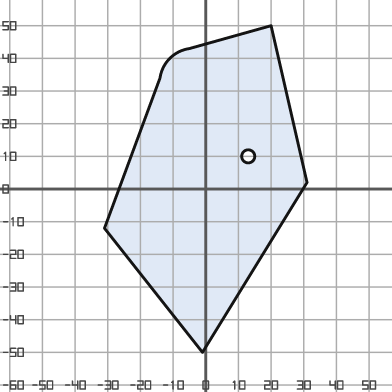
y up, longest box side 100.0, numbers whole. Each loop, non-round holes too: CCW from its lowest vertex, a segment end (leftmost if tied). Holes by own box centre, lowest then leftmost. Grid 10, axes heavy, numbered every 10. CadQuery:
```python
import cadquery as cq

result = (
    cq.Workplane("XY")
    .moveTo(-1.0, -50.0)
    .lineTo(31.0, 2.0)
    .lineTo(20.0, 50.0)
    .lineTo(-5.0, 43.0)
    .threePointArc((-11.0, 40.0), (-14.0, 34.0))
    .lineTo(-31.0, -12.0)
    .close()
    .moveTo(13.0, 10.0)
    .circle(2.0)
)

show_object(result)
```